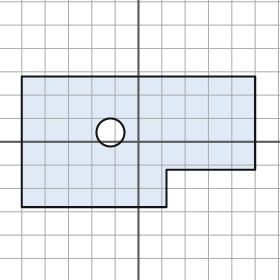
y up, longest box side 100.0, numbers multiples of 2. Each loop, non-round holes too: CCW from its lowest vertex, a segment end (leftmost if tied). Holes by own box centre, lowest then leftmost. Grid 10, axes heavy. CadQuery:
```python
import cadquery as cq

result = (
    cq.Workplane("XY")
    .moveTo(-50.0, -28.0)
    .lineTo(12.0, -28.0)
    .lineTo(12.0, -12.0)
    .lineTo(50.0, -12.0)
    .lineTo(50.0, 28.0)
    .lineTo(-50.0, 28.0)
    .close()
    .moveTo(-12.0, 4.0)
    .circle(6.0)
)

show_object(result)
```